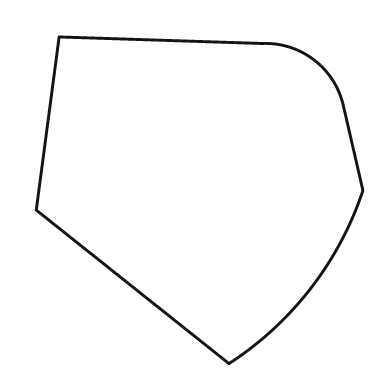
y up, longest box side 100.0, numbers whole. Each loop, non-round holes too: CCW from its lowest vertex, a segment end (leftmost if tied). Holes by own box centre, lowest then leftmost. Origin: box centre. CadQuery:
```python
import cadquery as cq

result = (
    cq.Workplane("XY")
    .moveTo(9.0, -50.0)
    .threePointArc((34.0, -27.0), (50.0, 3.0))
    .lineTo(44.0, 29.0)
    .threePointArc((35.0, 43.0), (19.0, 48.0))
    .lineTo(-43.0, 50.0)
    .lineTo(-50.0, -3.0)
    .close()
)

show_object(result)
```